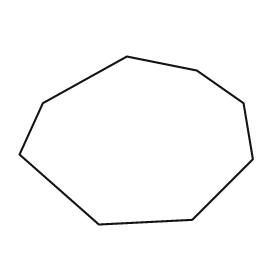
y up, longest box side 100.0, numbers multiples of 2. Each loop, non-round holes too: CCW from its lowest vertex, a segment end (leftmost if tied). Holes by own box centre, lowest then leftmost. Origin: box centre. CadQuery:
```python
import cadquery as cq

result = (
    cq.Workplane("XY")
    .moveTo(-16.0, -36.0)
    .lineTo(24.0, -34.0)
    .lineTo(50.0, -8.0)
    .lineTo(46.0, 16.0)
    .lineTo(26.0, 30.0)
    .lineTo(-4.0, 36.0)
    .lineTo(-40.0, 16.0)
    .lineTo(-50.0, -6.0)
    .close()
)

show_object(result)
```